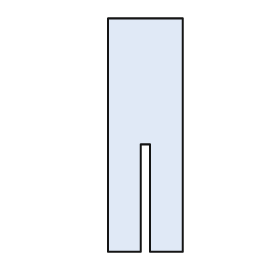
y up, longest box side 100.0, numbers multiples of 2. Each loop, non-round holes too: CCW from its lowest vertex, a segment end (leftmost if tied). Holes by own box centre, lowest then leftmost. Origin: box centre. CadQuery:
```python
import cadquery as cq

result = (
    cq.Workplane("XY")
    .moveTo(-16.0, -50.0)
    .lineTo(-2.0, -50.0)
    .lineTo(-2.0, -4.0)
    .lineTo(2.0, -4.0)
    .lineTo(2.0, -50.0)
    .lineTo(16.0, -50.0)
    .lineTo(16.0, 50.0)
    .lineTo(-16.0, 50.0)
    .close()
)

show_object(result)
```